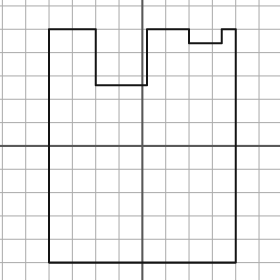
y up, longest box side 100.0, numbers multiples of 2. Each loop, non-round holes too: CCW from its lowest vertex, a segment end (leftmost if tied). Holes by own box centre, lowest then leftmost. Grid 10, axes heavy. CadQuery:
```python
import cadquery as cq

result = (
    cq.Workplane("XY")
    .moveTo(-40.0, -50.0)
    .lineTo(40.0, -50.0)
    .lineTo(40.0, 50.0)
    .lineTo(34.0, 50.0)
    .lineTo(34.0, 44.0)
    .lineTo(20.0, 44.0)
    .lineTo(20.0, 50.0)
    .lineTo(2.0, 50.0)
    .lineTo(2.0, 26.0)
    .lineTo(-20.0, 26.0)
    .lineTo(-20.0, 50.0)
    .lineTo(-40.0, 50.0)
    .close()
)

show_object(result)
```